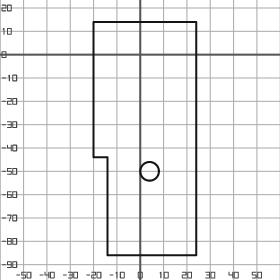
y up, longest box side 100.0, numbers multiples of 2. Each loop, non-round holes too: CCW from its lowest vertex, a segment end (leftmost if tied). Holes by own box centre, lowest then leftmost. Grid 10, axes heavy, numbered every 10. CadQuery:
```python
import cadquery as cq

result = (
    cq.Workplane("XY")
    .moveTo(-14.0, -86.0)
    .lineTo(24.0, -86.0)
    .lineTo(24.0, 14.0)
    .lineTo(-20.0, 14.0)
    .lineTo(-20.0, -44.0)
    .lineTo(-14.0, -44.0)
    .close()
    .moveTo(4.0, -50.0)
    .circle(4.0)
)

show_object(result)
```